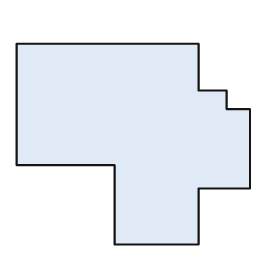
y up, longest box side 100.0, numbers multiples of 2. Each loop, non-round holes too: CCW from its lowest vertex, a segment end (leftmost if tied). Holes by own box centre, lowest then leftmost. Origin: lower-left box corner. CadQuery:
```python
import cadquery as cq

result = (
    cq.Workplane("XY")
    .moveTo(42.0, 0.0)
    .lineTo(78.0, 0.0)
    .lineTo(78.0, 24.0)
    .lineTo(100.0, 24.0)
    .lineTo(100.0, 58.0)
    .lineTo(90.0, 58.0)
    .lineTo(90.0, 66.0)
    .lineTo(78.0, 66.0)
    .lineTo(78.0, 86.0)
    .lineTo(0.0, 86.0)
    .lineTo(0.0, 34.0)
    .lineTo(42.0, 34.0)
    .close()
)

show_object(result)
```